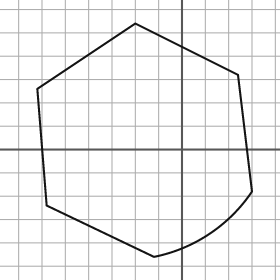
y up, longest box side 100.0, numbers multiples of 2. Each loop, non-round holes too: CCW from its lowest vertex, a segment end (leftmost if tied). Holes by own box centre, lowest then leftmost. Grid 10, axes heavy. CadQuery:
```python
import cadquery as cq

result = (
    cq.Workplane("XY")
    .moveTo(-12.0, -46.0)
    .threePointArc((12.0, -36.0), (30.0, -18.0))
    .lineTo(24.0, 32.0)
    .lineTo(-20.0, 54.0)
    .lineTo(-62.0, 26.0)
    .lineTo(-58.0, -24.0)
    .close()
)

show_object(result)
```